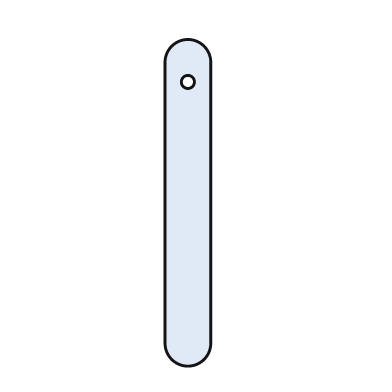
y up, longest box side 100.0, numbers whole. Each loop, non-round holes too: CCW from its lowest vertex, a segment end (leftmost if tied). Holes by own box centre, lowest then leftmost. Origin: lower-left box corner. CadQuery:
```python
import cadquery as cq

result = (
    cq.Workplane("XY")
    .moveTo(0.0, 7.0)
    .threePointArc((7.0, 0.0), (14.0, 7.0))
    .lineTo(14.0, 93.0)
    .threePointArc((7.0, 100.0), (0.0, 93.0))
    .close()
    .moveTo(7.0, 87.0)
    .circle(2.0)
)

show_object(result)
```